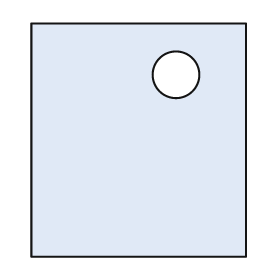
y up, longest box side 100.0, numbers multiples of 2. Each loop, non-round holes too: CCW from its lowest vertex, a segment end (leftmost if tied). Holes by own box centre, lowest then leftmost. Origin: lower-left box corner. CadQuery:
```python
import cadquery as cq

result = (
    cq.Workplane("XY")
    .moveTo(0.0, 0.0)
    .lineTo(92.0, 0.0)
    .lineTo(92.0, 100.0)
    .lineTo(0.0, 100.0)
    .close()
    .moveTo(62.0, 78.0)
    .circle(10.0)
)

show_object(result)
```